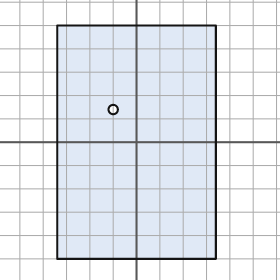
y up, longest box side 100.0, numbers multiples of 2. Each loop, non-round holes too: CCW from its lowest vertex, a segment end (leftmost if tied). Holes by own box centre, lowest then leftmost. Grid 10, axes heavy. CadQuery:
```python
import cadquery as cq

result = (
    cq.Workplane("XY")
    .moveTo(-34.0, -50.0)
    .lineTo(34.0, -50.0)
    .lineTo(34.0, 50.0)
    .lineTo(-34.0, 50.0)
    .close()
    .moveTo(-10.0, 14.0)
    .circle(2.0)
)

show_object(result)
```